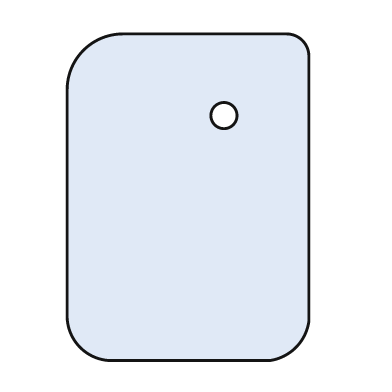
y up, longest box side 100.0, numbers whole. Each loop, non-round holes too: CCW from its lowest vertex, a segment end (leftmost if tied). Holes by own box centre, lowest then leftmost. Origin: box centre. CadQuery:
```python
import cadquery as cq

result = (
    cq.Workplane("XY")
    .moveTo(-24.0, -50.0)
    .lineTo(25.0, -50.0)
    .threePointArc((33.0, -46.0), (37.0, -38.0))
    .lineTo(37.0, 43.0)
    .threePointArc((35.0, 48.0), (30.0, 50.0))
    .lineTo(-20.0, 50.0)
    .threePointArc((-32.0, 45.0), (-37.0, 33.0))
    .lineTo(-37.0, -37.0)
    .threePointArc((-33.0, -46.0), (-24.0, -50.0))
    .close()
    .moveTo(11.0, 25.0)
    .circle(4.0)
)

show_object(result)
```